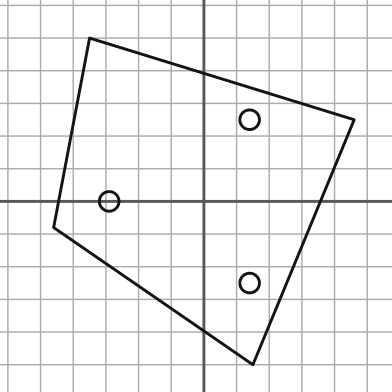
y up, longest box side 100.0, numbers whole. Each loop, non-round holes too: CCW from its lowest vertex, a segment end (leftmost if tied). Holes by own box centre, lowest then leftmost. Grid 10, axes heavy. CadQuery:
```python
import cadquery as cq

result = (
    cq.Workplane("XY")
    .moveTo(15.0, -50.0)
    .lineTo(46.0, 25.0)
    .lineTo(-35.0, 50.0)
    .lineTo(-46.0, -8.0)
    .close()
    .moveTo(14.0, -25.0)
    .circle(3.0)
    .moveTo(-29.0, 0.0)
    .circle(3.0)
    .moveTo(14.0, 25.0)
    .circle(3.0)
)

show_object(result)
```